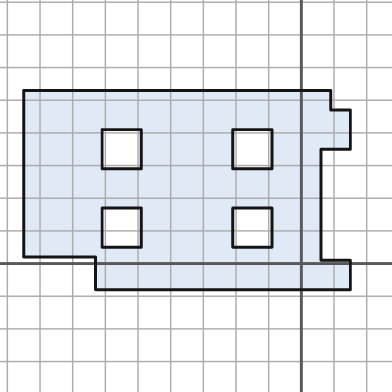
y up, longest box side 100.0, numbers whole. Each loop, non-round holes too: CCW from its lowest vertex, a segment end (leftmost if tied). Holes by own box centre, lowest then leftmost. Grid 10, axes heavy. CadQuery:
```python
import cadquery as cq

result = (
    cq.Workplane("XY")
    .moveTo(-63.0, -8.0)
    .lineTo(15.0, -8.0)
    .lineTo(15.0, 1.0)
    .lineTo(6.0, 1.0)
    .lineTo(6.0, 35.0)
    .lineTo(15.0, 35.0)
    .lineTo(15.0, 47.0)
    .lineTo(9.0, 47.0)
    .lineTo(9.0, 53.0)
    .lineTo(-85.0, 53.0)
    .lineTo(-85.0, 2.0)
    .lineTo(-63.0, 2.0)
    .close()
    .moveTo(-61.0, 5.0)
    .lineTo(-49.0, 5.0)
    .lineTo(-49.0, 17.0)
    .lineTo(-61.0, 17.0)
    .close()
    .moveTo(-21.0, 5.0)
    .lineTo(-9.0, 5.0)
    .lineTo(-9.0, 17.0)
    .lineTo(-21.0, 17.0)
    .close()
    .moveTo(-61.0, 29.0)
    .lineTo(-49.0, 29.0)
    .lineTo(-49.0, 41.0)
    .lineTo(-61.0, 41.0)
    .close()
    .moveTo(-21.0, 29.0)
    .lineTo(-9.0, 29.0)
    .lineTo(-9.0, 41.0)
    .lineTo(-21.0, 41.0)
    .close()
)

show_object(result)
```